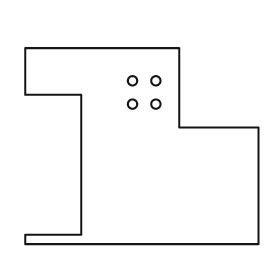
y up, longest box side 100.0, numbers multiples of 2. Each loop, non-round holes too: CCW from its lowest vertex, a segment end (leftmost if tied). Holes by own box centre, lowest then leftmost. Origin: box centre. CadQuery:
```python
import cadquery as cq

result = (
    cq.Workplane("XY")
    .moveTo(-50.0, -42.0)
    .lineTo(50.0, -42.0)
    .lineTo(50.0, 8.0)
    .lineTo(16.0, 8.0)
    .lineTo(16.0, 42.0)
    .lineTo(-50.0, 42.0)
    .lineTo(-50.0, 22.0)
    .lineTo(-26.0, 22.0)
    .lineTo(-26.0, -38.0)
    .lineTo(-50.0, -38.0)
    .close()
    .moveTo(-4.0, 18.0)
    .circle(2.0)
    .moveTo(6.0, 18.0)
    .circle(2.0)
    .moveTo(-4.0, 28.0)
    .circle(2.0)
    .moveTo(6.0, 28.0)
    .circle(2.0)
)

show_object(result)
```